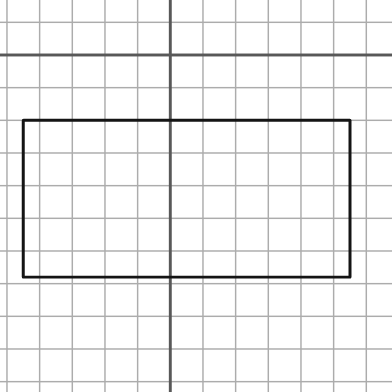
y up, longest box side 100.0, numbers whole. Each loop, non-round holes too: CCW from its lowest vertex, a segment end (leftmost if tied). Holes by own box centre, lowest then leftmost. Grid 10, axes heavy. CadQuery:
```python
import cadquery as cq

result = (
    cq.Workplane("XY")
    .moveTo(-45.0, -68.0)
    .lineTo(55.0, -68.0)
    .lineTo(55.0, -20.0)
    .lineTo(-45.0, -20.0)
    .close()
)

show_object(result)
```